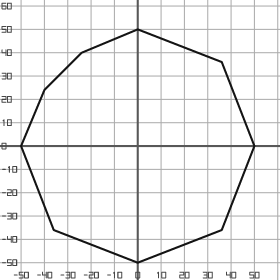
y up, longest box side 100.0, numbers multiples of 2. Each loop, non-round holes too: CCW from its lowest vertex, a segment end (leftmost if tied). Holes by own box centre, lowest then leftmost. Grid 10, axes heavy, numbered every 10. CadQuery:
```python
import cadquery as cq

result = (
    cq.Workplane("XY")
    .moveTo(0.0, -50.0)
    .lineTo(36.0, -36.0)
    .lineTo(50.0, 0.0)
    .lineTo(36.0, 36.0)
    .lineTo(0.0, 50.0)
    .lineTo(-24.0, 40.0)
    .lineTo(-40.0, 24.0)
    .lineTo(-50.0, 0.0)
    .lineTo(-36.0, -36.0)
    .close()
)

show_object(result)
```